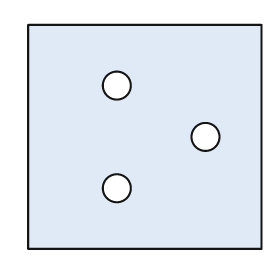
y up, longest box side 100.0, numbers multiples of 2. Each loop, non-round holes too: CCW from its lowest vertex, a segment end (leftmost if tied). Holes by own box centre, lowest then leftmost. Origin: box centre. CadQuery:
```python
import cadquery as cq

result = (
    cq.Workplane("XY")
    .moveTo(-50.0, -48.0)
    .lineTo(50.0, -48.0)
    .lineTo(50.0, 48.0)
    .lineTo(-50.0, 48.0)
    .close()
    .moveTo(-12.0, -22.0)
    .circle(6.0)
    .moveTo(26.0, 0.0)
    .circle(6.0)
    .moveTo(-12.0, 22.0)
    .circle(6.0)
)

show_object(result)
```